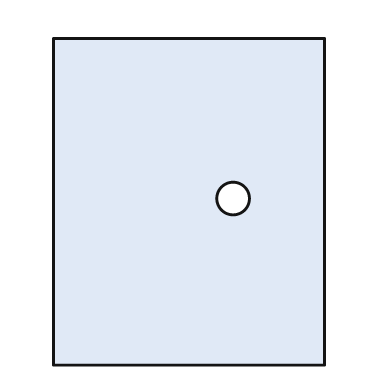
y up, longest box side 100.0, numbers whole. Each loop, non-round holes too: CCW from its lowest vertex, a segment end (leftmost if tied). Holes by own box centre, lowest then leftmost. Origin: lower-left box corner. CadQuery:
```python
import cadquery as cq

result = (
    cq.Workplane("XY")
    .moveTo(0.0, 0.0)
    .lineTo(83.0, 0.0)
    .lineTo(83.0, 100.0)
    .lineTo(0.0, 100.0)
    .close()
    .moveTo(55.0, 51.0)
    .circle(5.0)
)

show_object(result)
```